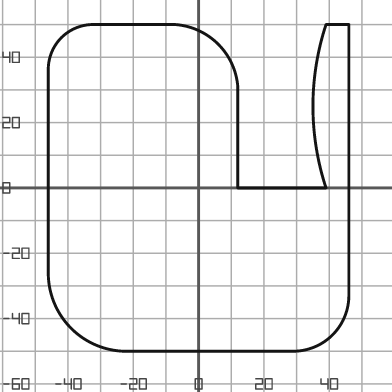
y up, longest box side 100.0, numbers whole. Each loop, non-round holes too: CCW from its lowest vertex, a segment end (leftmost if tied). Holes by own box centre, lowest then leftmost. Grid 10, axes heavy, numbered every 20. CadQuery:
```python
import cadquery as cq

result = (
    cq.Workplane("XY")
    .moveTo(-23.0, -50.0)
    .lineTo(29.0, -50.0)
    .threePointArc((41.0, -45.0), (46.0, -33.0))
    .lineTo(46.0, 50.0)
    .lineTo(39.0, 50.0)
    .threePointArc((35.0, 25.0), (39.0, 0.0))
    .lineTo(12.0, 0.0)
    .lineTo(12.0, 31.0)
    .threePointArc((6.0, 44.0), (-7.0, 50.0))
    .lineTo(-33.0, 50.0)
    .threePointArc((-42.0, 46.0), (-46.0, 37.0))
    .lineTo(-46.0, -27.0)
    .threePointArc((-39.0, -43.0), (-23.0, -50.0))
    .close()
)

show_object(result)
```